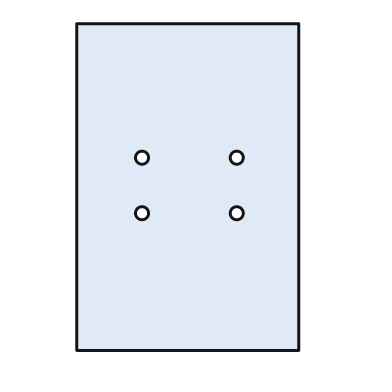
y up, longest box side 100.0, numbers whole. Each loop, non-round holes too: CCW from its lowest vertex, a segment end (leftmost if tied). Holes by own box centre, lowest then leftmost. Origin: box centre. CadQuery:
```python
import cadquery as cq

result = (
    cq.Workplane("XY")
    .moveTo(-34.0, -50.0)
    .lineTo(34.0, -50.0)
    .lineTo(34.0, 50.0)
    .lineTo(-34.0, 50.0)
    .close()
    .moveTo(-14.0, -8.0)
    .circle(2.0)
    .moveTo(15.0, -8.0)
    .circle(2.0)
    .moveTo(-14.0, 9.0)
    .circle(2.0)
    .moveTo(15.0, 9.0)
    .circle(2.0)
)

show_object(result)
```